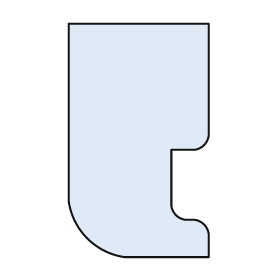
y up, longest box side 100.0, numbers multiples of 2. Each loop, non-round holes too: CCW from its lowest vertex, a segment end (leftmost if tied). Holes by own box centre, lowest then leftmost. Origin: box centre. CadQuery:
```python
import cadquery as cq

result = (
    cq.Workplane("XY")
    .moveTo(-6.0, -50.0)
    .lineTo(30.0, -50.0)
    .lineTo(30.0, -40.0)
    .threePointArc((28.0, -36.0), (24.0, -34.0))
    .lineTo(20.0, -34.0)
    .threePointArc((16.0, -32.0), (14.0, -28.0))
    .lineTo(14.0, -4.0)
    .lineTo(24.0, -4.0)
    .threePointArc((28.0, -2.0), (30.0, 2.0))
    .lineTo(30.0, 50.0)
    .lineTo(-30.0, 50.0)
    .lineTo(-30.0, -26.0)
    .threePointArc((-22.0, -42.0), (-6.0, -50.0))
    .close()
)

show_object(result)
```